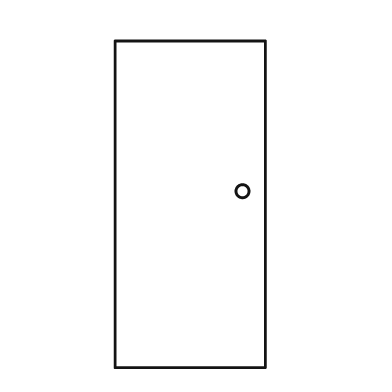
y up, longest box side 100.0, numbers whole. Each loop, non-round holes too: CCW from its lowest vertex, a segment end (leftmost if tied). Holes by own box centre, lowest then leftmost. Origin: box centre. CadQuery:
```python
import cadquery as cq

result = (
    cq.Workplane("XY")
    .moveTo(-23.0, -50.0)
    .lineTo(23.0, -50.0)
    .lineTo(23.0, 50.0)
    .lineTo(-23.0, 50.0)
    .close()
    .moveTo(16.0, 4.0)
    .circle(2.0)
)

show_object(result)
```